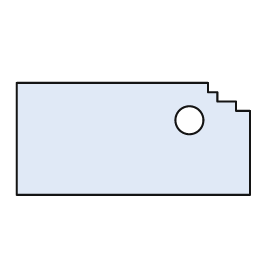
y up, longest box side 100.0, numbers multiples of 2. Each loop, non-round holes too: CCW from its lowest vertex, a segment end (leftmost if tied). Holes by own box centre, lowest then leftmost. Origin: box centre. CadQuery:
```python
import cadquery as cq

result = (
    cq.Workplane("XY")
    .moveTo(-50.0, -24.0)
    .lineTo(50.0, -24.0)
    .lineTo(50.0, 12.0)
    .lineTo(44.0, 12.0)
    .lineTo(44.0, 16.0)
    .lineTo(36.0, 16.0)
    .lineTo(36.0, 20.0)
    .lineTo(32.0, 20.0)
    .lineTo(32.0, 24.0)
    .lineTo(-50.0, 24.0)
    .close()
    .moveTo(24.0, 8.0)
    .circle(6.0)
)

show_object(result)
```